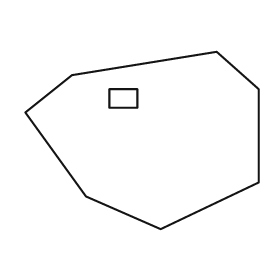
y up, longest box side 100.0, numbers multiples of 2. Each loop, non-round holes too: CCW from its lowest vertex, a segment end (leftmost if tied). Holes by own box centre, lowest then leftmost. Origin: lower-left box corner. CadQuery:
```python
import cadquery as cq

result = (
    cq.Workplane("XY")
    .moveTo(58.0, 0.0)
    .lineTo(100.0, 20.0)
    .lineTo(100.0, 60.0)
    .lineTo(82.0, 76.0)
    .lineTo(20.0, 66.0)
    .lineTo(0.0, 50.0)
    .lineTo(26.0, 14.0)
    .close()
    .moveTo(36.0, 52.0)
    .lineTo(48.0, 52.0)
    .lineTo(48.0, 60.0)
    .lineTo(36.0, 60.0)
    .close()
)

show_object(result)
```